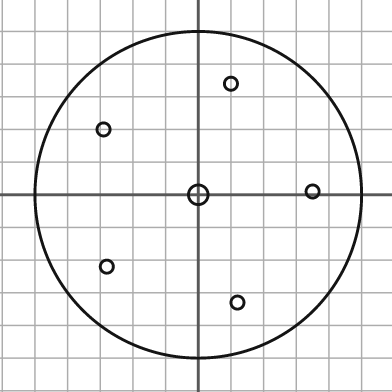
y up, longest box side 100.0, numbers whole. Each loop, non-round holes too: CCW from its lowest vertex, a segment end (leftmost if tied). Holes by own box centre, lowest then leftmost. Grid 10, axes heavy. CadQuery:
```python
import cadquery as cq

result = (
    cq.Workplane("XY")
    .moveTo(0.0, 0.0)
    .circle(50.0)
    .moveTo(12.0, -33.0)
    .circle(2.0)
    .moveTo(-28.0, -22.0)
    .circle(2.0)
    .moveTo(0.0, 0.0)
    .circle(3.0)
    .moveTo(35.0, 1.0)
    .circle(2.0)
    .moveTo(-29.0, 20.0)
    .circle(2.0)
    .moveTo(10.0, 34.0)
    .circle(2.0)
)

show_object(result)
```